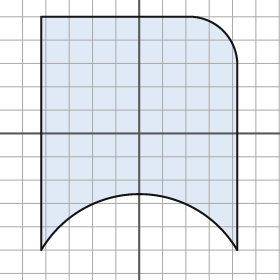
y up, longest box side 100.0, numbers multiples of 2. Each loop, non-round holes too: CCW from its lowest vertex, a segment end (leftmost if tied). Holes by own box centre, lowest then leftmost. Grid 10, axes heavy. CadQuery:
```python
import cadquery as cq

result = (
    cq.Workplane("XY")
    .moveTo(-42.0, -50.0)
    .threePointArc((0.0, -26.0), (42.0, -50.0))
    .lineTo(42.0, 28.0)
    .threePointArc((36.0, 44.0), (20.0, 50.0))
    .lineTo(-42.0, 50.0)
    .close()
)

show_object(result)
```